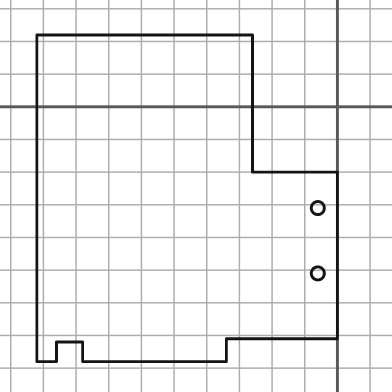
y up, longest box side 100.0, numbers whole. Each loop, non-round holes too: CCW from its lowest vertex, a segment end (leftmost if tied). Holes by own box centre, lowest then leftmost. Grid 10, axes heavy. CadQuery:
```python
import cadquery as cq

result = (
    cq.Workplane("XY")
    .moveTo(-92.0, -78.0)
    .lineTo(-86.0, -78.0)
    .lineTo(-86.0, -72.0)
    .lineTo(-78.0, -72.0)
    .lineTo(-78.0, -78.0)
    .lineTo(-34.0, -78.0)
    .lineTo(-34.0, -71.0)
    .lineTo(0.0, -71.0)
    .lineTo(0.0, -20.0)
    .lineTo(-26.0, -20.0)
    .lineTo(-26.0, 22.0)
    .lineTo(-92.0, 22.0)
    .close()
    .moveTo(-6.0, -51.0)
    .circle(2.0)
    .moveTo(-6.0, -31.0)
    .circle(2.0)
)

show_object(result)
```